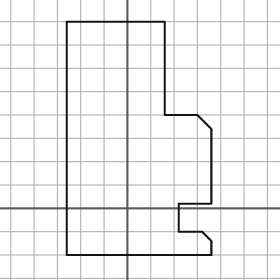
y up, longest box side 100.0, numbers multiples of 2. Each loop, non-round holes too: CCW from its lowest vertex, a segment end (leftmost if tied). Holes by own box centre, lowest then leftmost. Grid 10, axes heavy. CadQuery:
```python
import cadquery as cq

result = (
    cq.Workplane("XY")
    .moveTo(-26.0, -20.0)
    .lineTo(36.0, -20.0)
    .lineTo(36.0, -14.0)
    .lineTo(32.0, -10.0)
    .lineTo(22.0, -10.0)
    .lineTo(22.0, 2.0)
    .lineTo(36.0, 2.0)
    .lineTo(36.0, 34.0)
    .lineTo(30.0, 40.0)
    .lineTo(16.0, 40.0)
    .lineTo(16.0, 80.0)
    .lineTo(-26.0, 80.0)
    .close()
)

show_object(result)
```